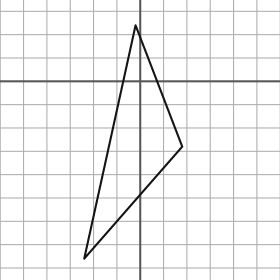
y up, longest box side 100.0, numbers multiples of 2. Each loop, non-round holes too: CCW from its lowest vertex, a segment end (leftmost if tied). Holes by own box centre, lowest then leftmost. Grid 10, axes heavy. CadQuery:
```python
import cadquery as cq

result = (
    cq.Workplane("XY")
    .moveTo(-24.0, -76.0)
    .lineTo(18.0, -28.0)
    .lineTo(-2.0, 24.0)
    .close()
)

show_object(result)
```